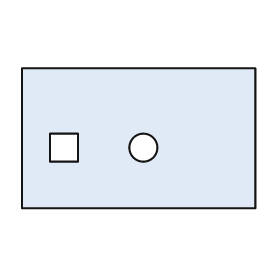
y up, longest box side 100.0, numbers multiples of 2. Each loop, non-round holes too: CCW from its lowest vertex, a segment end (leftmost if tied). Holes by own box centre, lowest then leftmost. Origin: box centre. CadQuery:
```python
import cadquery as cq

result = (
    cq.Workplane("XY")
    .moveTo(-50.0, -30.0)
    .lineTo(50.0, -30.0)
    .lineTo(50.0, 30.0)
    .lineTo(-50.0, 30.0)
    .close()
    .moveTo(-38.0, -10.0)
    .lineTo(-26.0, -10.0)
    .lineTo(-26.0, 2.0)
    .lineTo(-38.0, 2.0)
    .close()
    .moveTo(2.0, -4.0)
    .circle(6.0)
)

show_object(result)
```